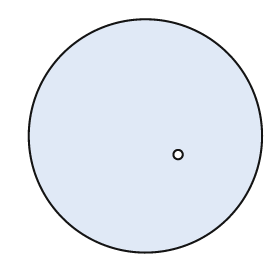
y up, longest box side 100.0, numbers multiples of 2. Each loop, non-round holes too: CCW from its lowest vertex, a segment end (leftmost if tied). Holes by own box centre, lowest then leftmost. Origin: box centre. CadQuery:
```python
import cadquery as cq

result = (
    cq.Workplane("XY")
    .moveTo(0.0, 0.0)
    .circle(50.0)
    .moveTo(14.0, -8.0)
    .circle(2.0)
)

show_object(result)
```